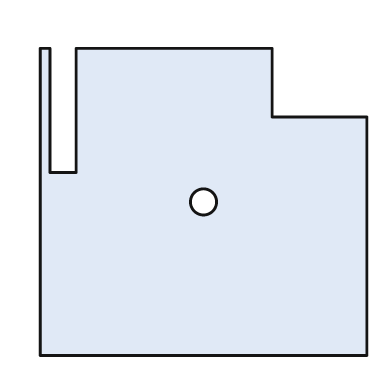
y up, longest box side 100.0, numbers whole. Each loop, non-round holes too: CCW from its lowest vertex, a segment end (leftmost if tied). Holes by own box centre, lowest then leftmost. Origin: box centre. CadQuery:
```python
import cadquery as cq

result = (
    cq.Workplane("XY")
    .moveTo(-50.0, -47.0)
    .lineTo(50.0, -47.0)
    .lineTo(50.0, 26.0)
    .lineTo(21.0, 26.0)
    .lineTo(21.0, 47.0)
    .lineTo(-39.0, 47.0)
    .lineTo(-39.0, 9.0)
    .lineTo(-47.0, 9.0)
    .lineTo(-47.0, 47.0)
    .lineTo(-50.0, 47.0)
    .close()
    .moveTo(0.0, 0.0)
    .circle(4.0)
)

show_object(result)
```